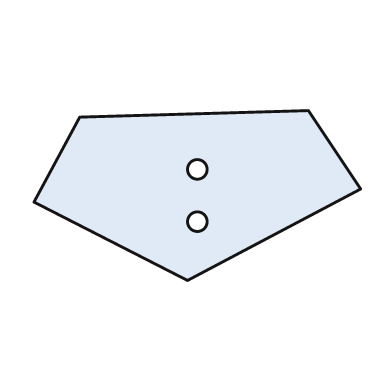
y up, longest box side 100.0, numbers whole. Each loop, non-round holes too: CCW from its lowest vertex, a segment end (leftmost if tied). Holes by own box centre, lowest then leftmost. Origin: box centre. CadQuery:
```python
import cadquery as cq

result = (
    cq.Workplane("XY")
    .moveTo(-3.0, -26.0)
    .lineTo(50.0, 2.0)
    .lineTo(34.0, 26.0)
    .lineTo(-36.0, 24.0)
    .lineTo(-50.0, -2.0)
    .close()
    .moveTo(0.0, -8.0)
    .circle(3.0)
    .moveTo(0.0, 8.0)
    .circle(3.0)
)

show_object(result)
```